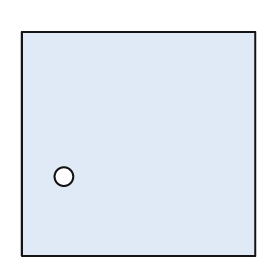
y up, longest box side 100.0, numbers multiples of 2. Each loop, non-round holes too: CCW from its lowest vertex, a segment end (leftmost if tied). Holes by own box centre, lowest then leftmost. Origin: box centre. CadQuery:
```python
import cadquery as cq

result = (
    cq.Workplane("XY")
    .moveTo(-50.0, -48.0)
    .lineTo(50.0, -48.0)
    .lineTo(50.0, 48.0)
    .lineTo(-50.0, 48.0)
    .close()
    .moveTo(-32.0, -14.0)
    .circle(4.0)
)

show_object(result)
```